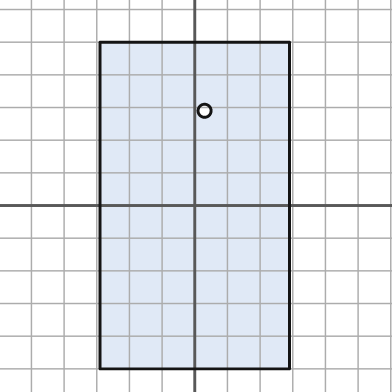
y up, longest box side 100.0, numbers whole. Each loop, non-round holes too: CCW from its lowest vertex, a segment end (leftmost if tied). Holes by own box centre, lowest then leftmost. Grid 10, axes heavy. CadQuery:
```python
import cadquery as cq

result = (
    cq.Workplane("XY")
    .moveTo(-29.0, -50.0)
    .lineTo(29.0, -50.0)
    .lineTo(29.0, 50.0)
    .lineTo(-29.0, 50.0)
    .close()
    .moveTo(3.0, 29.0)
    .circle(2.0)
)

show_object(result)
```